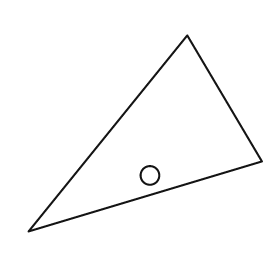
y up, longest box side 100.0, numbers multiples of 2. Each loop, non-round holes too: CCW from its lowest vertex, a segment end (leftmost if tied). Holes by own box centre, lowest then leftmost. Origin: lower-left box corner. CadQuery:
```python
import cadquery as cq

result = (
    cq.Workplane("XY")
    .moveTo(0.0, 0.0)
    .lineTo(100.0, 30.0)
    .lineTo(68.0, 84.0)
    .close()
    .moveTo(52.0, 24.0)
    .circle(4.0)
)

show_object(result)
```